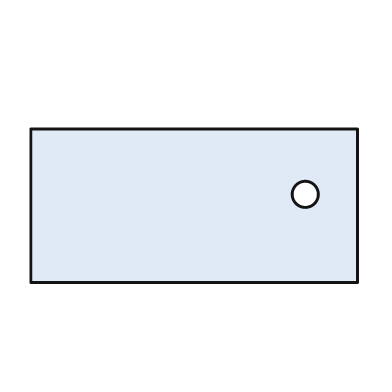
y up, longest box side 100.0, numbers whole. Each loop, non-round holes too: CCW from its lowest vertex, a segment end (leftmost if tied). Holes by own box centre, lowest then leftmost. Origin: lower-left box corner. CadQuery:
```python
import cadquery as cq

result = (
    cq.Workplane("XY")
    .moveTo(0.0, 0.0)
    .lineTo(100.0, 0.0)
    .lineTo(100.0, 47.0)
    .lineTo(0.0, 47.0)
    .close()
    .moveTo(84.0, 27.0)
    .circle(4.0)
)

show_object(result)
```